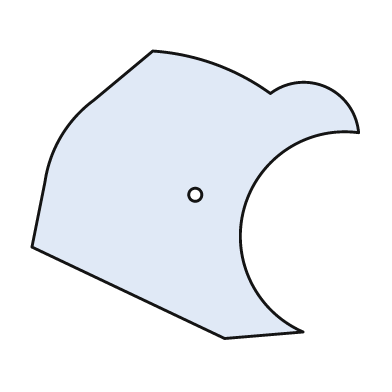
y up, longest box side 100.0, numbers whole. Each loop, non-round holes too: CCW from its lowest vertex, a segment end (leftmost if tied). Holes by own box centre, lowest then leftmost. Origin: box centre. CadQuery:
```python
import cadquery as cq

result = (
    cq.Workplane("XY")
    .moveTo(9.0, -44.0)
    .lineTo(33.0, -42.0)
    .threePointArc((15.0, -4.0), (50.0, 19.0))
    .threePointArc((40.0, 33.0), (23.0, 31.0))
    .threePointArc((6.0, 40.0), (-13.0, 44.0))
    .lineTo(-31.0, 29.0)
    .threePointArc((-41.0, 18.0), (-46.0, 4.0))
    .lineTo(-50.0, -16.0)
    .close()
    .moveTo(0.0, 0.0)
    .circle(2.0)
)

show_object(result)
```